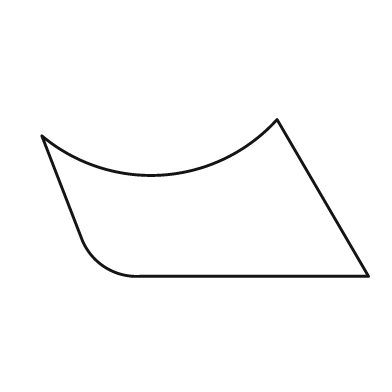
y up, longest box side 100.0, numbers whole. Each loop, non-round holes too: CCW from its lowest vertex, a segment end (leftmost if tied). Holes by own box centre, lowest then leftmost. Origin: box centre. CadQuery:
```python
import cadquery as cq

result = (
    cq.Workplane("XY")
    .moveTo(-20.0, -24.0)
    .lineTo(50.0, -24.0)
    .lineTo(22.0, 24.0)
    .threePointArc((-13.0, 7.0), (-50.0, 19.0))
    .lineTo(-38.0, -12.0)
    .threePointArc((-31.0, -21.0), (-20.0, -24.0))
    .close()
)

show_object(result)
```